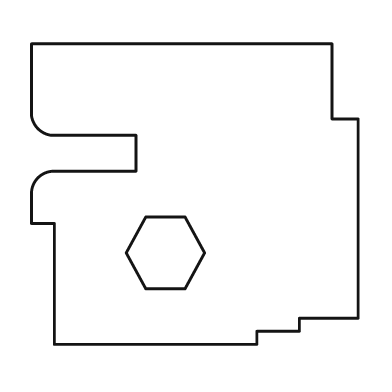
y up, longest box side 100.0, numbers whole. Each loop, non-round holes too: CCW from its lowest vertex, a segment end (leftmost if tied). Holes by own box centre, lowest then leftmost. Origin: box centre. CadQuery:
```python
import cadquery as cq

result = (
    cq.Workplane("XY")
    .moveTo(-43.0, -46.0)
    .lineTo(19.0, -46.0)
    .lineTo(19.0, -42.0)
    .lineTo(32.0, -42.0)
    .lineTo(32.0, -38.0)
    .lineTo(50.0, -38.0)
    .lineTo(50.0, 23.0)
    .lineTo(42.0, 23.0)
    .lineTo(42.0, 46.0)
    .lineTo(-50.0, 46.0)
    .lineTo(-50.0, 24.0)
    .threePointArc((-48.0, 20.0), (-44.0, 18.0))
    .lineTo(-18.0, 18.0)
    .lineTo(-18.0, 7.0)
    .lineTo(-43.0, 7.0)
    .threePointArc((-48.0, 5.0), (-50.0, 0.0))
    .lineTo(-50.0, -9.0)
    .lineTo(-43.0, -9.0)
    .close()
    .moveTo(-15.0, -29.0)
    .lineTo(-3.0, -29.0)
    .lineTo(3.0, -18.0)
    .lineTo(-3.0, -7.0)
    .lineTo(-15.0, -7.0)
    .lineTo(-21.0, -18.0)
    .close()
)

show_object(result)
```